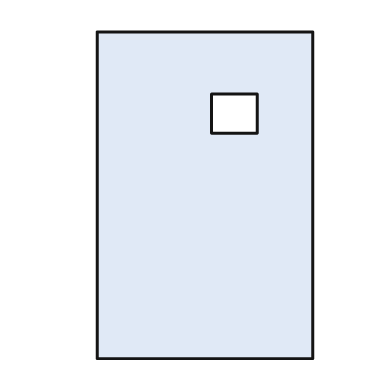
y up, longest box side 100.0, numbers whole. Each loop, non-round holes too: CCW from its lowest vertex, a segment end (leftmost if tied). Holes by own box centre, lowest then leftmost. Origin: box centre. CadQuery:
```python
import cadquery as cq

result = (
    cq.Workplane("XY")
    .moveTo(-33.0, -50.0)
    .lineTo(33.0, -50.0)
    .lineTo(33.0, 50.0)
    .lineTo(-33.0, 50.0)
    .close()
    .moveTo(2.0, 19.0)
    .lineTo(16.0, 19.0)
    .lineTo(16.0, 31.0)
    .lineTo(2.0, 31.0)
    .close()
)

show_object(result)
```